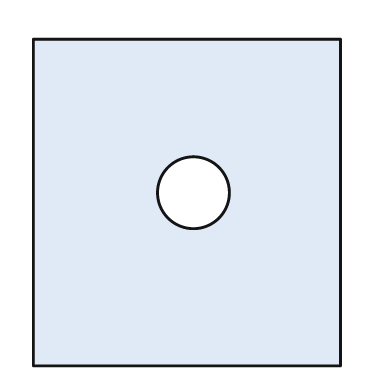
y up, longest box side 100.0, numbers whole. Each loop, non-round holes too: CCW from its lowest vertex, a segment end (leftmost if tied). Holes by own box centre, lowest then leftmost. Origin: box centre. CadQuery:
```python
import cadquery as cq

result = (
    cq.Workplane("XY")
    .moveTo(-47.0, -50.0)
    .lineTo(47.0, -50.0)
    .lineTo(47.0, 50.0)
    .lineTo(-47.0, 50.0)
    .close()
    .moveTo(2.0, 3.0)
    .circle(11.0)
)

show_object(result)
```